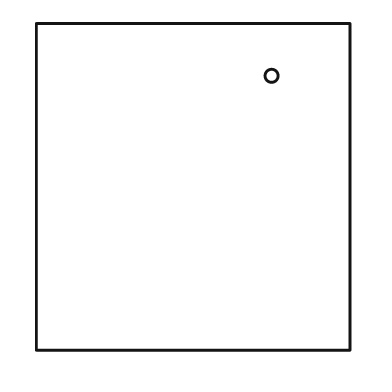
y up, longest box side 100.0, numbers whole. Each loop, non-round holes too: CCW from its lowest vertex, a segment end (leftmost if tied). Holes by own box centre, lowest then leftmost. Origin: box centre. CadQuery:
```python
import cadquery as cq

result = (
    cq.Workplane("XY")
    .moveTo(-48.0, -50.0)
    .lineTo(48.0, -50.0)
    .lineTo(48.0, 50.0)
    .lineTo(-48.0, 50.0)
    .close()
    .moveTo(24.0, 34.0)
    .circle(2.0)
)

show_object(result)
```